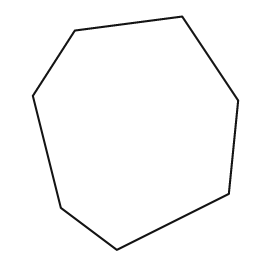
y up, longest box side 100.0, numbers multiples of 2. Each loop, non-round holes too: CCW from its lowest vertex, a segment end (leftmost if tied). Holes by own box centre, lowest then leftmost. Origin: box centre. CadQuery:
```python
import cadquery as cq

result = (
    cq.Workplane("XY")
    .moveTo(-8.0, -50.0)
    .lineTo(40.0, -26.0)
    .lineTo(44.0, 14.0)
    .lineTo(20.0, 50.0)
    .lineTo(-26.0, 44.0)
    .lineTo(-44.0, 16.0)
    .lineTo(-32.0, -32.0)
    .close()
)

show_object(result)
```